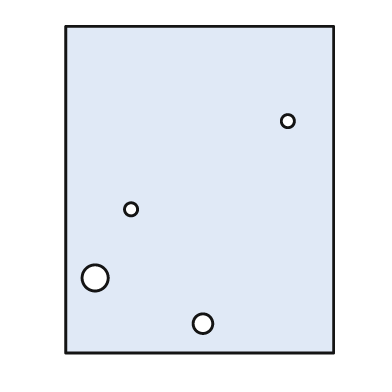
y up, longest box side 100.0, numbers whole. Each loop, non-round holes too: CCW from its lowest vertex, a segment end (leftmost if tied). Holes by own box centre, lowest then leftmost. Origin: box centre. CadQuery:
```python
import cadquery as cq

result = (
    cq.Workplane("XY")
    .moveTo(-41.0, -50.0)
    .lineTo(41.0, -50.0)
    .lineTo(41.0, 50.0)
    .lineTo(-41.0, 50.0)
    .close()
    .moveTo(1.0, -41.0)
    .circle(3.0)
    .moveTo(-32.0, -27.0)
    .circle(4.0)
    .moveTo(-21.0, -6.0)
    .circle(2.0)
    .moveTo(27.0, 21.0)
    .circle(2.0)
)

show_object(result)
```